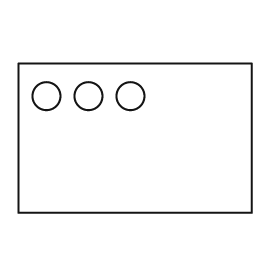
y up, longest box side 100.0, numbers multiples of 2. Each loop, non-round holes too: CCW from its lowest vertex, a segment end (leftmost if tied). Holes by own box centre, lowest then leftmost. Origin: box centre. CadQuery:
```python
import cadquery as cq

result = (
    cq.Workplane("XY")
    .moveTo(-50.0, -32.0)
    .lineTo(50.0, -32.0)
    .lineTo(50.0, 32.0)
    .lineTo(-50.0, 32.0)
    .close()
    .moveTo(-38.0, 18.0)
    .circle(6.0)
    .moveTo(-20.0, 18.0)
    .circle(6.0)
    .moveTo(-2.0, 18.0)
    .circle(6.0)
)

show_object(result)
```